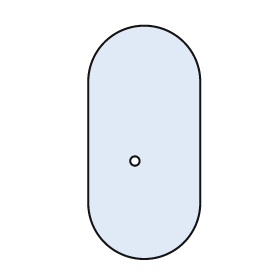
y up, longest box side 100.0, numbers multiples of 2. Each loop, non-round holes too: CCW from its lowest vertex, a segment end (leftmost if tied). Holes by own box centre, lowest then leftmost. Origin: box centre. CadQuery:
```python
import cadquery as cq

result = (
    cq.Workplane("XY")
    .moveTo(-24.0, -26.0)
    .threePointArc((0.0, -50.0), (24.0, -26.0))
    .lineTo(24.0, 26.0)
    .threePointArc((0.0, 50.0), (-24.0, 26.0))
    .close()
    .moveTo(-4.0, -8.0)
    .circle(2.0)
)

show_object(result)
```